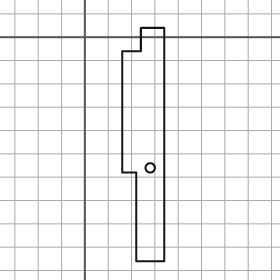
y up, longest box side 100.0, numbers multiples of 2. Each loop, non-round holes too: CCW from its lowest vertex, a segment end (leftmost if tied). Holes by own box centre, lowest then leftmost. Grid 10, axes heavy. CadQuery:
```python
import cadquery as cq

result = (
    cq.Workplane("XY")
    .moveTo(22.0, -96.0)
    .lineTo(34.0, -96.0)
    .lineTo(34.0, 4.0)
    .lineTo(24.0, 4.0)
    .lineTo(24.0, -6.0)
    .lineTo(16.0, -6.0)
    .lineTo(16.0, -58.0)
    .lineTo(22.0, -58.0)
    .close()
    .moveTo(28.0, -56.0)
    .circle(2.0)
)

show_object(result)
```